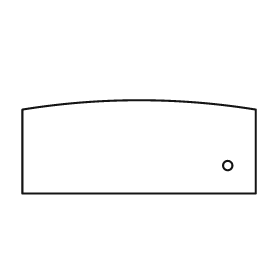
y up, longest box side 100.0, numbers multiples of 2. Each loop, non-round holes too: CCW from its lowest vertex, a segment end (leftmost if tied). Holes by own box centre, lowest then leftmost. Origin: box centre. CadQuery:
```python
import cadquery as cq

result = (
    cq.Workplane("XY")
    .moveTo(-50.0, -20.0)
    .lineTo(50.0, -20.0)
    .lineTo(50.0, 16.0)
    .threePointArc((0.0, 20.0), (-50.0, 16.0))
    .close()
    .moveTo(38.0, -8.0)
    .circle(2.0)
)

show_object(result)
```